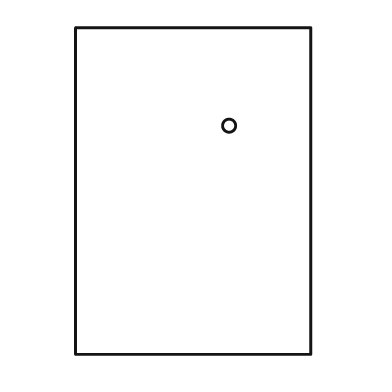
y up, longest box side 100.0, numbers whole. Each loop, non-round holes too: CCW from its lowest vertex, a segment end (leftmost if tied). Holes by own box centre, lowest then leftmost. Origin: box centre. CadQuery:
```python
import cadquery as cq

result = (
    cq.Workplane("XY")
    .moveTo(-36.0, -50.0)
    .lineTo(36.0, -50.0)
    .lineTo(36.0, 50.0)
    .lineTo(-36.0, 50.0)
    .close()
    .moveTo(11.0, 20.0)
    .circle(2.0)
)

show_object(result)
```